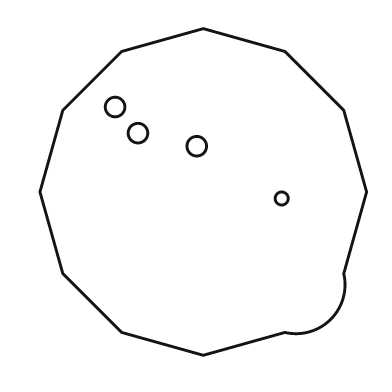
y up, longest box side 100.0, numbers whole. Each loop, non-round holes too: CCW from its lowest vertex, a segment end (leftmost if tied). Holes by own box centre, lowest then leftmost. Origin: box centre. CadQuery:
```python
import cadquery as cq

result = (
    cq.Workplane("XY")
    .moveTo(0.0, -50.0)
    .lineTo(25.0, -43.0)
    .threePointArc((39.0, -39.0), (43.0, -25.0))
    .lineTo(50.0, 0.0)
    .lineTo(43.0, 25.0)
    .lineTo(25.0, 43.0)
    .lineTo(0.0, 50.0)
    .lineTo(-25.0, 43.0)
    .lineTo(-43.0, 25.0)
    .lineTo(-50.0, 0.0)
    .lineTo(-43.0, -25.0)
    .lineTo(-25.0, -43.0)
    .close()
    .moveTo(24.0, -2.0)
    .circle(2.0)
    .moveTo(-2.0, 14.0)
    .circle(3.0)
    .moveTo(-20.0, 18.0)
    .circle(3.0)
    .moveTo(-27.0, 26.0)
    .circle(3.0)
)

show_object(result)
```